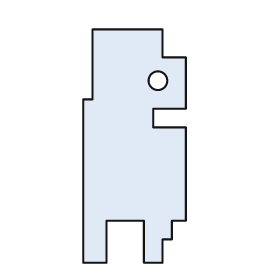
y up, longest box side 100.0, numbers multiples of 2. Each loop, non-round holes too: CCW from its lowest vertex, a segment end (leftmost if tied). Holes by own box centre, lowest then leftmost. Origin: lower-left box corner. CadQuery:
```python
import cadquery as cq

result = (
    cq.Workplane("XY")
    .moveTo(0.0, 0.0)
    .lineTo(10.0, 0.0)
    .lineTo(10.0, 18.0)
    .lineTo(26.0, 18.0)
    .lineTo(26.0, 0.0)
    .lineTo(34.0, 0.0)
    .lineTo(34.0, 10.0)
    .lineTo(38.0, 10.0)
    .lineTo(38.0, 18.0)
    .lineTo(44.0, 18.0)
    .lineTo(44.0, 58.0)
    .lineTo(30.0, 58.0)
    .lineTo(30.0, 66.0)
    .lineTo(44.0, 66.0)
    .lineTo(44.0, 88.0)
    .lineTo(34.0, 88.0)
    .lineTo(34.0, 100.0)
    .lineTo(4.0, 100.0)
    .lineTo(4.0, 70.0)
    .lineTo(0.0, 70.0)
    .close()
    .moveTo(32.0, 78.0)
    .circle(4.0)
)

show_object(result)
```